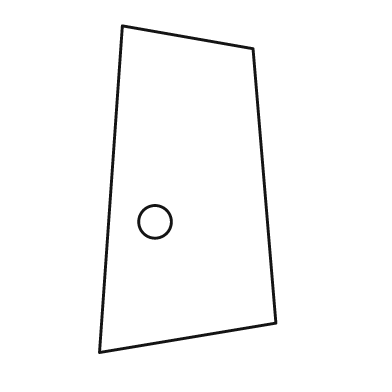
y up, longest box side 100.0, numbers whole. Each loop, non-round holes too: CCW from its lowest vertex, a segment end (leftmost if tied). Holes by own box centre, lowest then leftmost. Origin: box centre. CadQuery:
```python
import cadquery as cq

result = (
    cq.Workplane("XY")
    .moveTo(-27.0, -50.0)
    .lineTo(27.0, -41.0)
    .lineTo(20.0, 43.0)
    .lineTo(-20.0, 50.0)
    .close()
    .moveTo(-10.0, -10.0)
    .circle(5.0)
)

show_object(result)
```